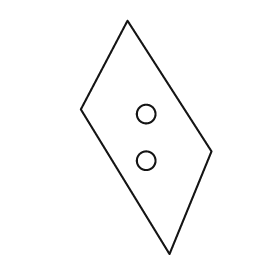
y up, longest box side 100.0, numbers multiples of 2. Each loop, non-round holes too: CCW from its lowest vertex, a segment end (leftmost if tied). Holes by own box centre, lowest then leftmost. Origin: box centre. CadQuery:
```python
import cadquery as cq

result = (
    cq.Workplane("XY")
    .moveTo(10.0, -50.0)
    .lineTo(28.0, -6.0)
    .lineTo(-8.0, 50.0)
    .lineTo(-28.0, 12.0)
    .close()
    .moveTo(0.0, -10.0)
    .circle(4.0)
    .moveTo(0.0, 10.0)
    .circle(4.0)
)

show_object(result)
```